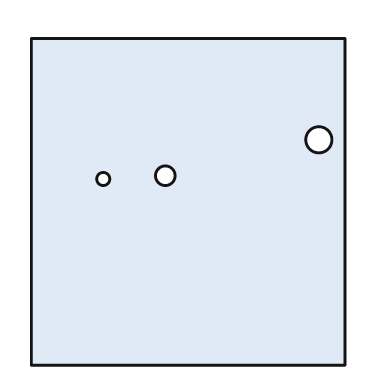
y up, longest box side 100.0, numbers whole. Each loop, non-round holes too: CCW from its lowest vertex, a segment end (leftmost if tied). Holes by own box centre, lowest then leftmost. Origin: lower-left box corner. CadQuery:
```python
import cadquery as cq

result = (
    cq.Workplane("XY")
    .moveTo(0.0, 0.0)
    .lineTo(96.0, 0.0)
    .lineTo(96.0, 100.0)
    .lineTo(0.0, 100.0)
    .close()
    .moveTo(22.0, 57.0)
    .circle(2.0)
    .moveTo(41.0, 58.0)
    .circle(3.0)
    .moveTo(88.0, 69.0)
    .circle(4.0)
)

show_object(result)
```